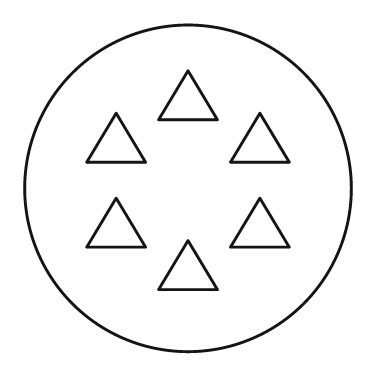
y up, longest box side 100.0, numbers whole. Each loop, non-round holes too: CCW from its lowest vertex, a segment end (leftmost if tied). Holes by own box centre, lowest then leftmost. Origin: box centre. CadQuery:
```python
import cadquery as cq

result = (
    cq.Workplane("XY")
    .moveTo(0.0, 0.0)
    .circle(50.0)
    .moveTo(-9.0, -31.0)
    .lineTo(9.0, -31.0)
    .lineTo(0.0, -16.0)
    .close()
    .moveTo(-31.0, -18.0)
    .lineTo(-13.0, -18.0)
    .lineTo(-22.0, -3.0)
    .close()
    .moveTo(13.0, -18.0)
    .lineTo(31.0, -18.0)
    .lineTo(22.0, -3.0)
    .close()
    .moveTo(-31.0, 8.0)
    .lineTo(-13.0, 8.0)
    .lineTo(-22.0, 23.0)
    .close()
    .moveTo(13.0, 8.0)
    .lineTo(31.0, 8.0)
    .lineTo(22.0, 23.0)
    .close()
    .moveTo(-9.0, 21.0)
    .lineTo(9.0, 21.0)
    .lineTo(0.0, 36.0)
    .close()
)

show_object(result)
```